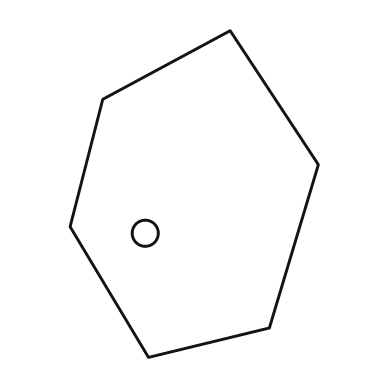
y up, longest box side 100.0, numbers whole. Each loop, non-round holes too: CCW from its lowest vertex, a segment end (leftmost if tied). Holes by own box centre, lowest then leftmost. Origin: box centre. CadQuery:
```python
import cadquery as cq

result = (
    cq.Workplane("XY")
    .moveTo(-14.0, -50.0)
    .lineTo(23.0, -41.0)
    .lineTo(38.0, 9.0)
    .lineTo(11.0, 50.0)
    .lineTo(-28.0, 29.0)
    .lineTo(-38.0, -10.0)
    .close()
    .moveTo(-15.0, -12.0)
    .circle(4.0)
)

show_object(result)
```